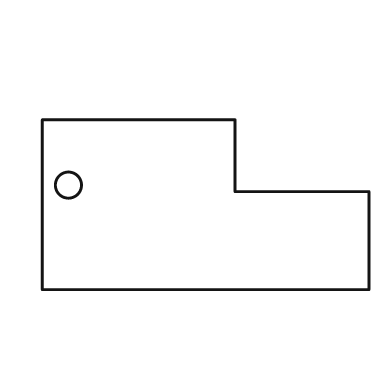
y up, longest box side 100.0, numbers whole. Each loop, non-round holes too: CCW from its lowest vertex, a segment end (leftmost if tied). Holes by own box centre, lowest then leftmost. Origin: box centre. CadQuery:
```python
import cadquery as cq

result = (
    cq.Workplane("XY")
    .moveTo(-50.0, -26.0)
    .lineTo(50.0, -26.0)
    .lineTo(50.0, 4.0)
    .lineTo(9.0, 4.0)
    .lineTo(9.0, 26.0)
    .lineTo(-50.0, 26.0)
    .close()
    .moveTo(-42.0, 6.0)
    .circle(4.0)
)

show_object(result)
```